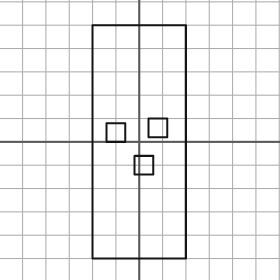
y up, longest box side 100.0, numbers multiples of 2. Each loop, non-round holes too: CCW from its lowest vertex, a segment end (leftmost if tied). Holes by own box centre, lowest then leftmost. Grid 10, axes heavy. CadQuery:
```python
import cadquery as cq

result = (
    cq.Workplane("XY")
    .moveTo(-20.0, -50.0)
    .lineTo(20.0, -50.0)
    .lineTo(20.0, 50.0)
    .lineTo(-20.0, 50.0)
    .close()
    .moveTo(-2.0, -14.0)
    .lineTo(6.0, -14.0)
    .lineTo(6.0, -6.0)
    .lineTo(-2.0, -6.0)
    .close()
    .moveTo(-14.0, 0.0)
    .lineTo(-6.0, 0.0)
    .lineTo(-6.0, 8.0)
    .lineTo(-14.0, 8.0)
    .close()
    .moveTo(4.0, 2.0)
    .lineTo(12.0, 2.0)
    .lineTo(12.0, 10.0)
    .lineTo(4.0, 10.0)
    .close()
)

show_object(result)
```